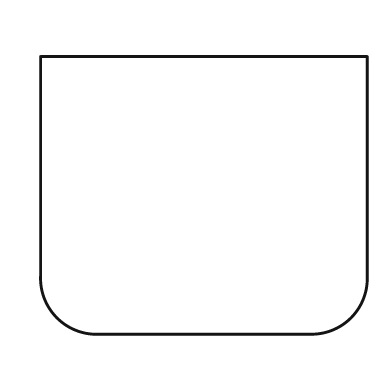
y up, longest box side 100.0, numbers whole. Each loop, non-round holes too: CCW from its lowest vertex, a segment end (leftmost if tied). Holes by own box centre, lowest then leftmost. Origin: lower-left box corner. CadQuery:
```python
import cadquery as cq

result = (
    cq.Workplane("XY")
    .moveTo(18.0, 0.0)
    .lineTo(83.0, 0.0)
    .threePointArc((95.0, 5.0), (100.0, 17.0))
    .lineTo(100.0, 85.0)
    .lineTo(0.0, 85.0)
    .lineTo(0.0, 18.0)
    .threePointArc((5.0, 5.0), (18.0, 0.0))
    .close()
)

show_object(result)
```